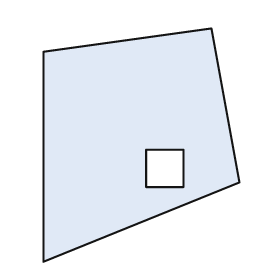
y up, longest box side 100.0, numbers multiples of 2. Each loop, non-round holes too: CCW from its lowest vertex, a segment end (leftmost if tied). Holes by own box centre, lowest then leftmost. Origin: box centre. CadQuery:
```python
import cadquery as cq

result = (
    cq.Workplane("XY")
    .moveTo(-42.0, -50.0)
    .lineTo(42.0, -16.0)
    .lineTo(30.0, 50.0)
    .lineTo(-42.0, 40.0)
    .close()
    .moveTo(2.0, -18.0)
    .lineTo(18.0, -18.0)
    .lineTo(18.0, -2.0)
    .lineTo(2.0, -2.0)
    .close()
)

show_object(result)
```